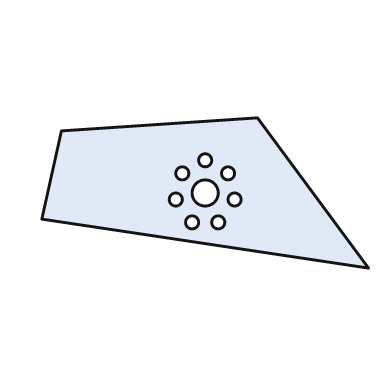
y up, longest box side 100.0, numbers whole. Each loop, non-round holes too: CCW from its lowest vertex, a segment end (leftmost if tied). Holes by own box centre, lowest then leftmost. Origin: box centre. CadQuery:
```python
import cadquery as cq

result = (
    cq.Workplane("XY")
    .moveTo(50.0, -23.0)
    .lineTo(16.0, 23.0)
    .lineTo(-44.0, 19.0)
    .lineTo(-50.0, -8.0)
    .close()
    .moveTo(-4.0, -9.0)
    .circle(2.0)
    .moveTo(4.0, -9.0)
    .circle(2.0)
    .moveTo(-9.0, -2.0)
    .circle(2.0)
    .moveTo(9.0, -2.0)
    .circle(2.0)
    .moveTo(0.0, 0.0)
    .circle(4.0)
    .moveTo(-7.0, 6.0)
    .circle(2.0)
    .moveTo(7.0, 6.0)
    .circle(2.0)
    .moveTo(0.0, 10.0)
    .circle(2.0)
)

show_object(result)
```